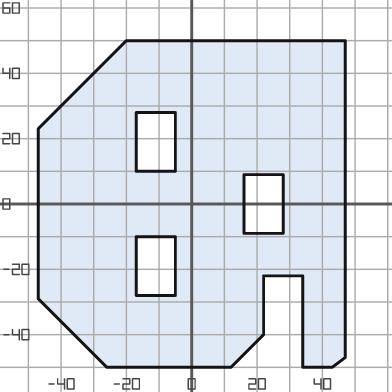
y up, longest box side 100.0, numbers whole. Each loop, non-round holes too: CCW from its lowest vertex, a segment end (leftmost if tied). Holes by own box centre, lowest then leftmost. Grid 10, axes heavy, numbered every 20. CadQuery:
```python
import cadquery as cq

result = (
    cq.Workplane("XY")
    .moveTo(-26.0, -50.0)
    .lineTo(12.0, -50.0)
    .lineTo(22.0, -40.0)
    .lineTo(22.0, -22.0)
    .lineTo(34.0, -22.0)
    .lineTo(34.0, -50.0)
    .lineTo(43.0, -50.0)
    .lineTo(47.0, -47.0)
    .lineTo(47.0, 50.0)
    .lineTo(-20.0, 50.0)
    .lineTo(-47.0, 23.0)
    .lineTo(-47.0, -29.0)
    .close()
    .moveTo(-17.0, -28.0)
    .lineTo(-5.0, -28.0)
    .lineTo(-5.0, -10.0)
    .lineTo(-17.0, -10.0)
    .close()
    .moveTo(16.0, -9.0)
    .lineTo(28.0, -9.0)
    .lineTo(28.0, 9.0)
    .lineTo(16.0, 9.0)
    .close()
    .moveTo(-17.0, 10.0)
    .lineTo(-5.0, 10.0)
    .lineTo(-5.0, 28.0)
    .lineTo(-17.0, 28.0)
    .close()
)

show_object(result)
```